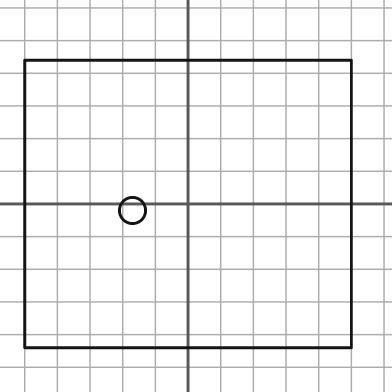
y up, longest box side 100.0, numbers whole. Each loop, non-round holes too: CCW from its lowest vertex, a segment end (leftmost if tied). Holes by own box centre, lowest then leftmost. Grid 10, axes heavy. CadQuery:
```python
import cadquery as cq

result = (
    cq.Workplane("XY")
    .moveTo(-50.0, -44.0)
    .lineTo(50.0, -44.0)
    .lineTo(50.0, 44.0)
    .lineTo(-50.0, 44.0)
    .close()
    .moveTo(-17.0, -2.0)
    .circle(4.0)
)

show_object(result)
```